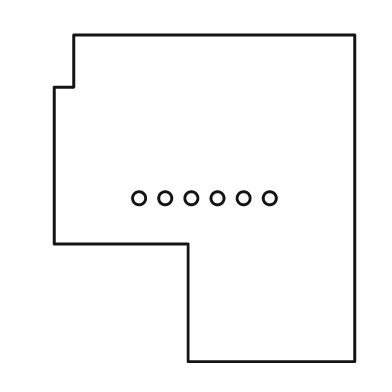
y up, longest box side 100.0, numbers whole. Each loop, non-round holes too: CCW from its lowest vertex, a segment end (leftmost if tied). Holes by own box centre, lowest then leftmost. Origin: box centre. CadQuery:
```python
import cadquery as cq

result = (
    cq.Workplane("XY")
    .moveTo(-5.0, -50.0)
    .lineTo(46.0, -50.0)
    .lineTo(46.0, 50.0)
    .lineTo(-40.0, 50.0)
    .lineTo(-40.0, 34.0)
    .lineTo(-46.0, 34.0)
    .lineTo(-46.0, -14.0)
    .lineTo(-5.0, -14.0)
    .close()
    .moveTo(-20.0, 0.0)
    .circle(2.0)
    .moveTo(-12.0, 0.0)
    .circle(2.0)
    .moveTo(-4.0, 0.0)
    .circle(2.0)
    .moveTo(4.0, 0.0)
    .circle(2.0)
    .moveTo(12.0, 0.0)
    .circle(2.0)
    .moveTo(20.0, 0.0)
    .circle(2.0)
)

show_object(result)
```